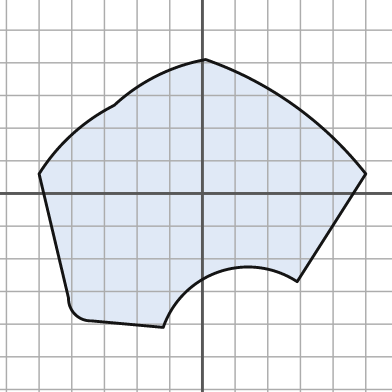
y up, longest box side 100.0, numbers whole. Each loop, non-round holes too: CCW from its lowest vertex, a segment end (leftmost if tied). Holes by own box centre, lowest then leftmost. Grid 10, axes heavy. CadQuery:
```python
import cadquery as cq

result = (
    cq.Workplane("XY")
    .moveTo(-12.0, -41.0)
    .threePointArc((5.0, -24.0), (29.0, -27.0))
    .lineTo(50.0, 6.0)
    .threePointArc((28.0, 27.0), (1.0, 41.0))
    .threePointArc((-14.0, 36.0), (-27.0, 27.0))
    .threePointArc((-40.0, 18.0), (-50.0, 6.0))
    .lineTo(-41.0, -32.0)
    .threePointArc((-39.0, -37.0), (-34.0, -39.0))
    .close()
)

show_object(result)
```